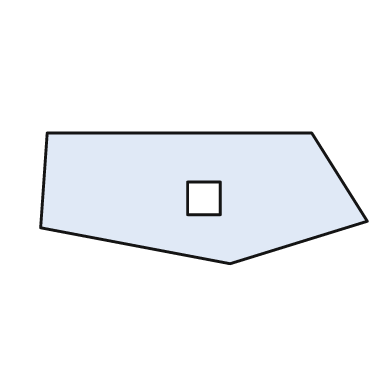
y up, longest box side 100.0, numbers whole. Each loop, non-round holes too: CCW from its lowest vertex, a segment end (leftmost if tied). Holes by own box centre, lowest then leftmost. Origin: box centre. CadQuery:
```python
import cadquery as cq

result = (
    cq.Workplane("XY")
    .moveTo(8.0, -20.0)
    .lineTo(50.0, -7.0)
    .lineTo(33.0, 20.0)
    .lineTo(-48.0, 20.0)
    .lineTo(-50.0, -9.0)
    .close()
    .moveTo(-5.0, -5.0)
    .lineTo(5.0, -5.0)
    .lineTo(5.0, 5.0)
    .lineTo(-5.0, 5.0)
    .close()
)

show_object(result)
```